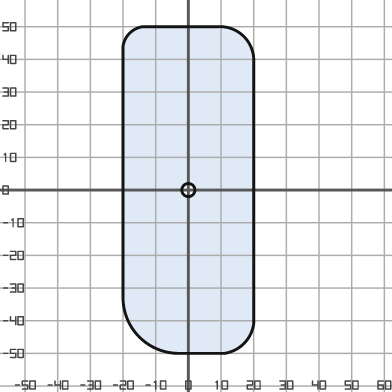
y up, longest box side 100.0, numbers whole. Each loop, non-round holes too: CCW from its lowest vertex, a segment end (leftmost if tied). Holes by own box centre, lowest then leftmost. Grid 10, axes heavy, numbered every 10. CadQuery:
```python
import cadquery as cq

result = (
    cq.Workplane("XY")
    .moveTo(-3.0, -50.0)
    .lineTo(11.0, -50.0)
    .threePointArc((17.0, -47.0), (20.0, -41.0))
    .lineTo(20.0, 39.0)
    .threePointArc((17.0, 47.0), (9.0, 50.0))
    .lineTo(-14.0, 50.0)
    .threePointArc((-18.0, 48.0), (-20.0, 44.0))
    .lineTo(-20.0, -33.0)
    .threePointArc((-15.0, -45.0), (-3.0, -50.0))
    .close()
    .moveTo(0.0, 0.0)
    .circle(2.0)
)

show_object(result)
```